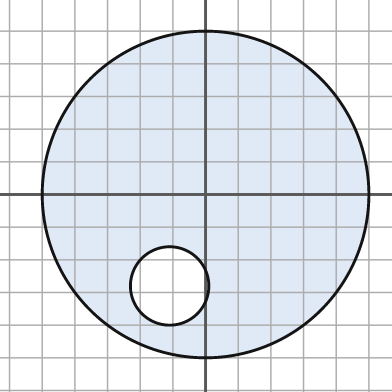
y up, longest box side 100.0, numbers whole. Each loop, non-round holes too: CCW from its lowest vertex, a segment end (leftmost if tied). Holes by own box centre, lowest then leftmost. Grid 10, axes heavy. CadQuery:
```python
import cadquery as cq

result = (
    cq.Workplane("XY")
    .moveTo(0.0, 0.0)
    .circle(50.0)
    .moveTo(-11.0, -28.0)
    .circle(12.0)
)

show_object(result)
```